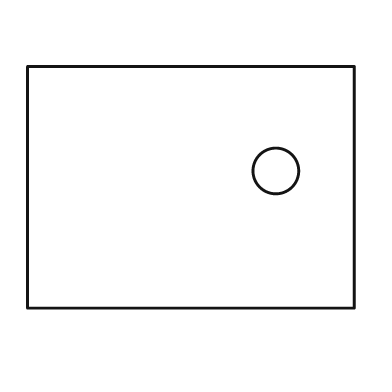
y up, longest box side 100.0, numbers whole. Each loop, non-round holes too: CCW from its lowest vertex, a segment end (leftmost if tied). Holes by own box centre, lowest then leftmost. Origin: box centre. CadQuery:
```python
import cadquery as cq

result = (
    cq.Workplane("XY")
    .moveTo(-50.0, -37.0)
    .lineTo(50.0, -37.0)
    .lineTo(50.0, 37.0)
    .lineTo(-50.0, 37.0)
    .close()
    .moveTo(26.0, 5.0)
    .circle(7.0)
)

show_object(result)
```